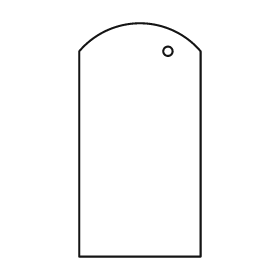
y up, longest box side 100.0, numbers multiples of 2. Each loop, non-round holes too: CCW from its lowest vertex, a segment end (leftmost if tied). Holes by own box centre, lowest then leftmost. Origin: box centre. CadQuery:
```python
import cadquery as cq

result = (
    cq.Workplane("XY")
    .moveTo(-26.0, -50.0)
    .lineTo(26.0, -50.0)
    .lineTo(26.0, 38.0)
    .threePointArc((0.0, 50.0), (-26.0, 38.0))
    .close()
    .moveTo(12.0, 38.0)
    .circle(2.0)
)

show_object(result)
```